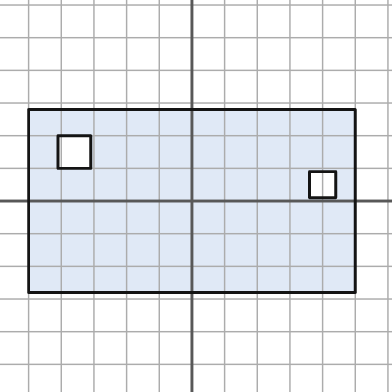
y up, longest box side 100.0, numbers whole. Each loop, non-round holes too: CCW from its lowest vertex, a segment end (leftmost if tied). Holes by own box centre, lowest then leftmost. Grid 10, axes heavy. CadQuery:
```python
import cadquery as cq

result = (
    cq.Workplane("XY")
    .moveTo(-50.0, -28.0)
    .lineTo(50.0, -28.0)
    .lineTo(50.0, 28.0)
    .lineTo(-50.0, 28.0)
    .close()
    .moveTo(36.0, 1.0)
    .lineTo(44.0, 1.0)
    .lineTo(44.0, 9.0)
    .lineTo(36.0, 9.0)
    .close()
    .moveTo(-41.0, 10.0)
    .lineTo(-31.0, 10.0)
    .lineTo(-31.0, 20.0)
    .lineTo(-41.0, 20.0)
    .close()
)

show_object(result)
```